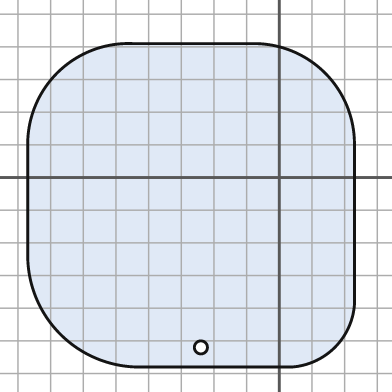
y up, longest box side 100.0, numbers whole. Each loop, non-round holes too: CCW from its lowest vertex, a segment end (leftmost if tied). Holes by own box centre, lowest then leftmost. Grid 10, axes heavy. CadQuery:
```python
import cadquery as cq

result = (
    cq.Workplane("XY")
    .moveTo(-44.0, -58.0)
    .lineTo(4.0, -58.0)
    .threePointArc((17.0, -52.0), (23.0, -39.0))
    .lineTo(23.0, 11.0)
    .threePointArc((14.0, 32.0), (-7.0, 41.0))
    .lineTo(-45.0, 41.0)
    .threePointArc((-68.0, 32.0), (-77.0, 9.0))
    .lineTo(-77.0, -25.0)
    .threePointArc((-67.0, -48.0), (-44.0, -58.0))
    .close()
    .moveTo(-24.0, -52.0)
    .circle(2.0)
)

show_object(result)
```